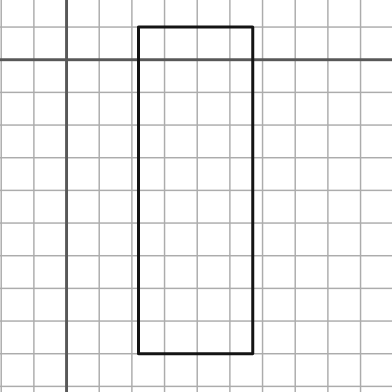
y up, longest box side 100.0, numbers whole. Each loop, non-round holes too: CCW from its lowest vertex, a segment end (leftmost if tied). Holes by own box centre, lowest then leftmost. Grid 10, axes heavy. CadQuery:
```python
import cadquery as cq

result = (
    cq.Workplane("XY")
    .moveTo(22.0, -90.0)
    .lineTo(57.0, -90.0)
    .lineTo(57.0, 10.0)
    .lineTo(22.0, 10.0)
    .close()
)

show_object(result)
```